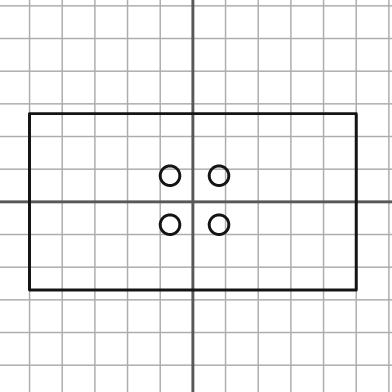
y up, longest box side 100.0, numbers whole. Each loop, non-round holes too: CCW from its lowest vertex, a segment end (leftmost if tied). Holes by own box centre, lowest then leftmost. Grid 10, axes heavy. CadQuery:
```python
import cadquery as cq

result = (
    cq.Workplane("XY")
    .moveTo(-50.0, -27.0)
    .lineTo(50.0, -27.0)
    .lineTo(50.0, 27.0)
    .lineTo(-50.0, 27.0)
    .close()
    .moveTo(-7.0, -7.0)
    .circle(3.0)
    .moveTo(8.0, -7.0)
    .circle(3.0)
    .moveTo(-7.0, 8.0)
    .circle(3.0)
    .moveTo(8.0, 8.0)
    .circle(3.0)
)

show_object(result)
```